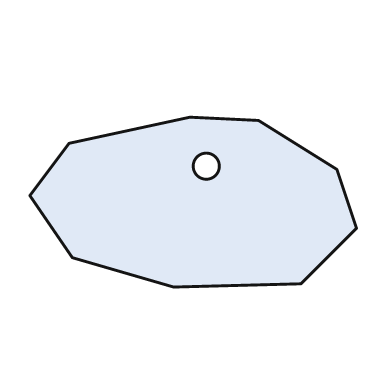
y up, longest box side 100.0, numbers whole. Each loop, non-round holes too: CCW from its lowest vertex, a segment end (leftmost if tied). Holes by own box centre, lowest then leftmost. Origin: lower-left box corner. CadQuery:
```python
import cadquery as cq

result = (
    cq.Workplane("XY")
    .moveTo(44.0, 0.0)
    .lineTo(83.0, 1.0)
    .lineTo(100.0, 18.0)
    .lineTo(94.0, 36.0)
    .lineTo(70.0, 51.0)
    .lineTo(49.0, 52.0)
    .lineTo(12.0, 44.0)
    .lineTo(0.0, 28.0)
    .lineTo(13.0, 9.0)
    .close()
    .moveTo(54.0, 37.0)
    .circle(4.0)
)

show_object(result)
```